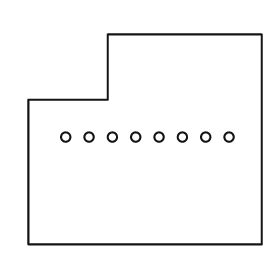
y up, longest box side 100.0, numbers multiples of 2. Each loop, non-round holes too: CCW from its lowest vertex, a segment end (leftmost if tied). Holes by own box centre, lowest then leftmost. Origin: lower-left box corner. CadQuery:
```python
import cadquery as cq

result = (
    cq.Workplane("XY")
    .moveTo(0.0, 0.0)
    .lineTo(100.0, 0.0)
    .lineTo(100.0, 90.0)
    .lineTo(34.0, 90.0)
    .lineTo(34.0, 62.0)
    .lineTo(0.0, 62.0)
    .close()
    .moveTo(16.0, 46.0)
    .circle(2.0)
    .moveTo(26.0, 46.0)
    .circle(2.0)
    .moveTo(36.0, 46.0)
    .circle(2.0)
    .moveTo(46.0, 46.0)
    .circle(2.0)
    .moveTo(56.0, 46.0)
    .circle(2.0)
    .moveTo(66.0, 46.0)
    .circle(2.0)
    .moveTo(76.0, 46.0)
    .circle(2.0)
    .moveTo(86.0, 46.0)
    .circle(2.0)
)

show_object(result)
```